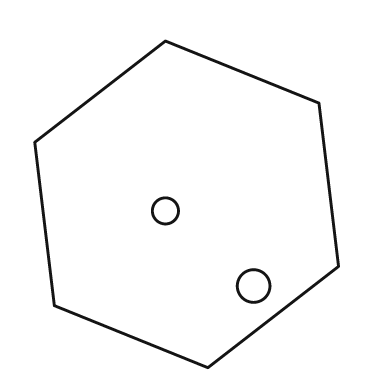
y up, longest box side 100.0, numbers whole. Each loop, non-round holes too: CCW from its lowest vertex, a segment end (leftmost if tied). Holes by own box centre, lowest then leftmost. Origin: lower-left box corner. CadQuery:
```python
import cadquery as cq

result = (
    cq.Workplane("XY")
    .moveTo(53.0, 0.0)
    .lineTo(93.0, 31.0)
    .lineTo(87.0, 81.0)
    .lineTo(40.0, 100.0)
    .lineTo(0.0, 69.0)
    .lineTo(6.0, 19.0)
    .close()
    .moveTo(67.0, 25.0)
    .circle(5.0)
    .moveTo(40.0, 48.0)
    .circle(4.0)
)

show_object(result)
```